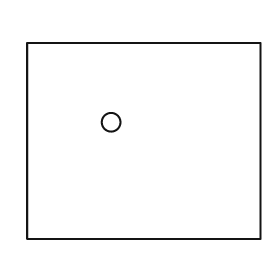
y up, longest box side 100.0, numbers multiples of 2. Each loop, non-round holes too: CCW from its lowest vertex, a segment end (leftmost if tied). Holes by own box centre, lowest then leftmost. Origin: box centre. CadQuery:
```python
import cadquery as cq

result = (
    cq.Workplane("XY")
    .moveTo(-50.0, -42.0)
    .lineTo(50.0, -42.0)
    .lineTo(50.0, 42.0)
    .lineTo(-50.0, 42.0)
    .close()
    .moveTo(-14.0, 8.0)
    .circle(4.0)
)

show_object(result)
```